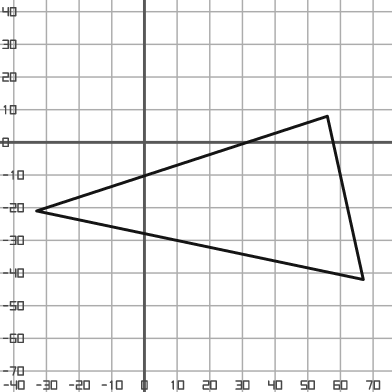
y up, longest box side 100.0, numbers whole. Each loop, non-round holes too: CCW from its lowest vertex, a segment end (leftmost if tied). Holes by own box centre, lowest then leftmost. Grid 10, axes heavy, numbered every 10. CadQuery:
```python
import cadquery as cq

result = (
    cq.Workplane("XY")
    .moveTo(67.0, -42.0)
    .lineTo(56.0, 8.0)
    .lineTo(-33.0, -21.0)
    .close()
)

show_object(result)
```